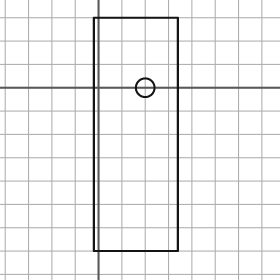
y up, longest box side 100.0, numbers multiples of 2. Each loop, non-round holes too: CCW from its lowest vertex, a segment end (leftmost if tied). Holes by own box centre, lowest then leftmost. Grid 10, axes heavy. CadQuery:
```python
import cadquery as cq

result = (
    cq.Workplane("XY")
    .moveTo(-2.0, -70.0)
    .lineTo(34.0, -70.0)
    .lineTo(34.0, 30.0)
    .lineTo(-2.0, 30.0)
    .close()
    .moveTo(20.0, 0.0)
    .circle(4.0)
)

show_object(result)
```